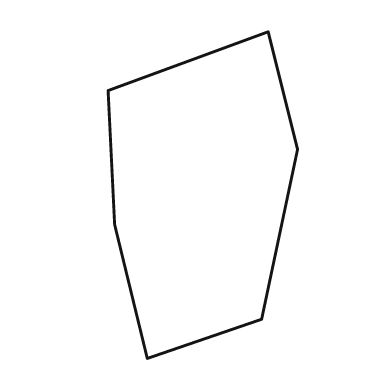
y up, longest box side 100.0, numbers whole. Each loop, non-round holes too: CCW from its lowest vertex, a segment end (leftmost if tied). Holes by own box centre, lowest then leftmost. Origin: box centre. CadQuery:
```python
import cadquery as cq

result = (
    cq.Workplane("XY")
    .moveTo(-17.0, -50.0)
    .lineTo(18.0, -38.0)
    .lineTo(29.0, 14.0)
    .lineTo(20.0, 50.0)
    .lineTo(-29.0, 32.0)
    .lineTo(-27.0, -9.0)
    .close()
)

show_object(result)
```